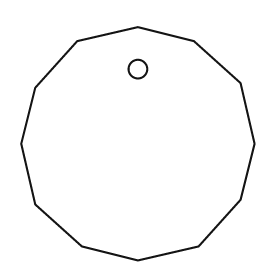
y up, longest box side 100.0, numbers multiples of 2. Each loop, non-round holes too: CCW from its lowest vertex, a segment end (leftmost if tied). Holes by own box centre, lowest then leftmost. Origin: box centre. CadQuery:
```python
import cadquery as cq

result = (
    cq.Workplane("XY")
    .moveTo(0.0, -50.0)
    .lineTo(26.0, -44.0)
    .lineTo(44.0, -24.0)
    .lineTo(50.0, 0.0)
    .lineTo(44.0, 26.0)
    .lineTo(24.0, 44.0)
    .lineTo(0.0, 50.0)
    .lineTo(-26.0, 44.0)
    .lineTo(-44.0, 24.0)
    .lineTo(-50.0, 0.0)
    .lineTo(-44.0, -26.0)
    .lineTo(-24.0, -44.0)
    .close()
    .moveTo(0.0, 32.0)
    .circle(4.0)
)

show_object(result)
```